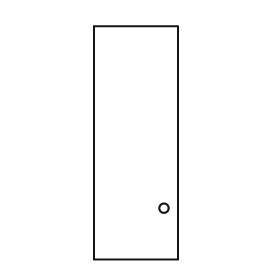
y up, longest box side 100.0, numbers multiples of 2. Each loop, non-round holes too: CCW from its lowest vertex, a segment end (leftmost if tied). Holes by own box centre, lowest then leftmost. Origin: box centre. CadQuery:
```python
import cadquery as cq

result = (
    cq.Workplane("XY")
    .moveTo(-18.0, -50.0)
    .lineTo(18.0, -50.0)
    .lineTo(18.0, 50.0)
    .lineTo(-18.0, 50.0)
    .close()
    .moveTo(12.0, -28.0)
    .circle(2.0)
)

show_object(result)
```